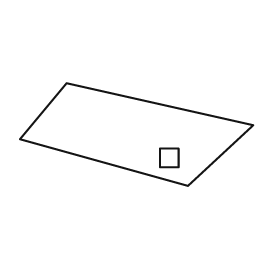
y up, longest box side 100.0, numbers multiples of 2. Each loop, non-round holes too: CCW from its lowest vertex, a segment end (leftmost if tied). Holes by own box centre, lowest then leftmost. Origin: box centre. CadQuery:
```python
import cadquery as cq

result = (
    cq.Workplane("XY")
    .moveTo(22.0, -22.0)
    .lineTo(50.0, 4.0)
    .lineTo(-30.0, 22.0)
    .lineTo(-50.0, -2.0)
    .close()
    .moveTo(10.0, -14.0)
    .lineTo(18.0, -14.0)
    .lineTo(18.0, -6.0)
    .lineTo(10.0, -6.0)
    .close()
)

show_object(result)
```